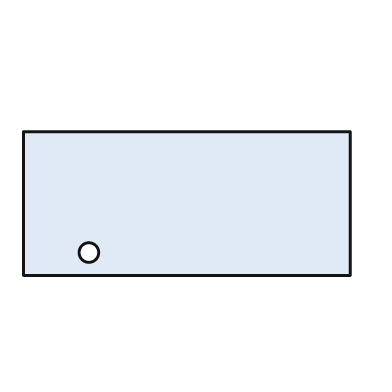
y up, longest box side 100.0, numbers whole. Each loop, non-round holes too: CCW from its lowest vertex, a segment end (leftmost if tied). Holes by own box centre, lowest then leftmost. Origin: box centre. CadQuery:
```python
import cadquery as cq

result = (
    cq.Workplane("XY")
    .moveTo(-50.0, -22.0)
    .lineTo(50.0, -22.0)
    .lineTo(50.0, 22.0)
    .lineTo(-50.0, 22.0)
    .close()
    .moveTo(-30.0, -15.0)
    .circle(3.0)
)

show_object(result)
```